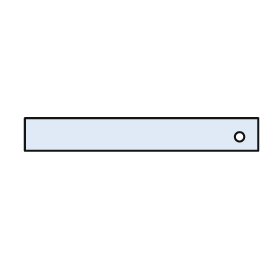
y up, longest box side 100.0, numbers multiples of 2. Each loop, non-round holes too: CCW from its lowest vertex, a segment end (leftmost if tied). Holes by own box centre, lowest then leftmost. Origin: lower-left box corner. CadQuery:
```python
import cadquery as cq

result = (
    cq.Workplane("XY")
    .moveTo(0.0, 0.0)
    .lineTo(100.0, 0.0)
    .lineTo(100.0, 14.0)
    .lineTo(0.0, 14.0)
    .close()
    .moveTo(92.0, 6.0)
    .circle(2.0)
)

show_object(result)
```